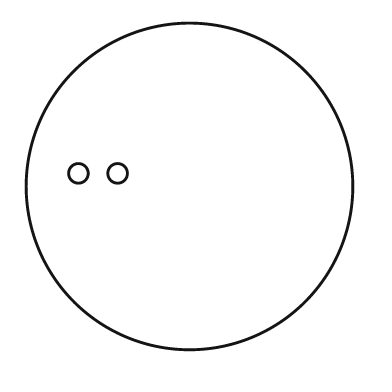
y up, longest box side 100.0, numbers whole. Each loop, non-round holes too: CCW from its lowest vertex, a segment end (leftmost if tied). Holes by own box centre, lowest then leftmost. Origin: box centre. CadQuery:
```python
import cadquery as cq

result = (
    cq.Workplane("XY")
    .moveTo(0.0, 0.0)
    .circle(50.0)
    .moveTo(-34.0, 4.0)
    .circle(3.0)
    .moveTo(-22.0, 4.0)
    .circle(3.0)
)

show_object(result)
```